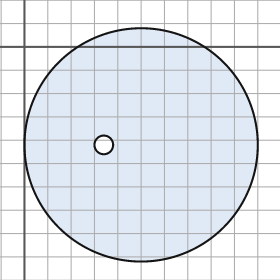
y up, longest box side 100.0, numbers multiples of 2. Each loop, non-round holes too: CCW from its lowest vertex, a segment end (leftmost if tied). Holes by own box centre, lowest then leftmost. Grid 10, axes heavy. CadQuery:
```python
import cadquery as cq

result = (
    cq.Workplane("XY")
    .moveTo(50.0, -42.0)
    .circle(50.0)
    .moveTo(34.0, -42.0)
    .circle(4.0)
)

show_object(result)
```